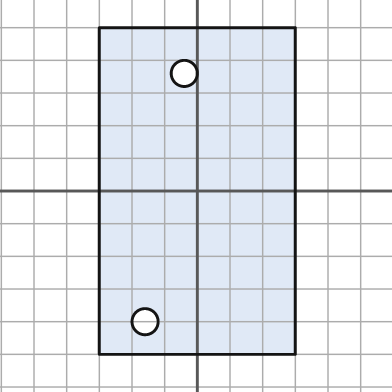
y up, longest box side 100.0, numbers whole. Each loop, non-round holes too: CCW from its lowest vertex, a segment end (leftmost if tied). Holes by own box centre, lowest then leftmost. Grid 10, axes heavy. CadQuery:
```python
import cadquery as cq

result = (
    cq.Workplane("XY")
    .moveTo(-30.0, -50.0)
    .lineTo(30.0, -50.0)
    .lineTo(30.0, 50.0)
    .lineTo(-30.0, 50.0)
    .close()
    .moveTo(-16.0, -40.0)
    .circle(4.0)
    .moveTo(-4.0, 36.0)
    .circle(4.0)
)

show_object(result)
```